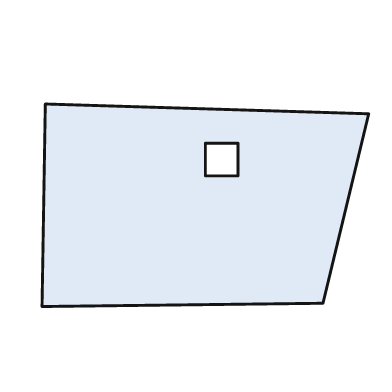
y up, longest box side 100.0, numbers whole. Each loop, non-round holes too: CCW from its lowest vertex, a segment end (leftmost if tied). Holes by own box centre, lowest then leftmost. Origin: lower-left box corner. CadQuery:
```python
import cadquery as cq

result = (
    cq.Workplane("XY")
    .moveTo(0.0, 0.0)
    .lineTo(86.0, 1.0)
    .lineTo(100.0, 59.0)
    .lineTo(1.0, 62.0)
    .close()
    .moveTo(50.0, 40.0)
    .lineTo(60.0, 40.0)
    .lineTo(60.0, 50.0)
    .lineTo(50.0, 50.0)
    .close()
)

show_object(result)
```